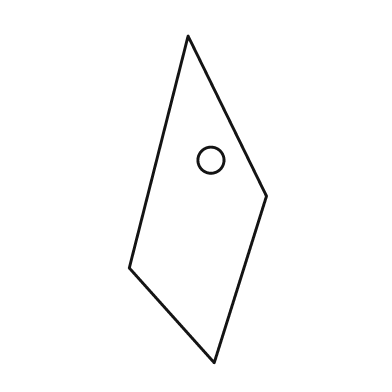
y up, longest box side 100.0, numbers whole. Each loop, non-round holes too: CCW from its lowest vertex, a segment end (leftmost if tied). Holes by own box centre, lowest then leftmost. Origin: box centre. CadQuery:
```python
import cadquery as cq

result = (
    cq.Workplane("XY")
    .moveTo(5.0, -50.0)
    .lineTo(21.0, 1.0)
    .lineTo(-3.0, 50.0)
    .lineTo(-21.0, -21.0)
    .close()
    .moveTo(4.0, 12.0)
    .circle(4.0)
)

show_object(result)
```